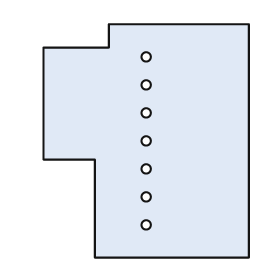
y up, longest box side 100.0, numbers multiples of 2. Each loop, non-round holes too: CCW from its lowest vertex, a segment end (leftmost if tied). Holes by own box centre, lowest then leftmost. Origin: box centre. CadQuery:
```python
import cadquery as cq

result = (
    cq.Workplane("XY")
    .moveTo(-22.0, -50.0)
    .lineTo(44.0, -50.0)
    .lineTo(44.0, 50.0)
    .lineTo(-16.0, 50.0)
    .lineTo(-16.0, 40.0)
    .lineTo(-44.0, 40.0)
    .lineTo(-44.0, -8.0)
    .lineTo(-22.0, -8.0)
    .close()
    .moveTo(0.0, -36.0)
    .circle(2.0)
    .moveTo(0.0, -24.0)
    .circle(2.0)
    .moveTo(0.0, -12.0)
    .circle(2.0)
    .moveTo(0.0, 0.0)
    .circle(2.0)
    .moveTo(0.0, 12.0)
    .circle(2.0)
    .moveTo(0.0, 24.0)
    .circle(2.0)
    .moveTo(0.0, 36.0)
    .circle(2.0)
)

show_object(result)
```